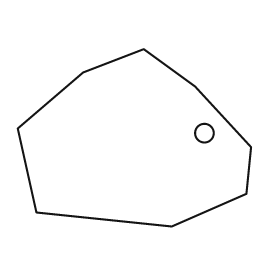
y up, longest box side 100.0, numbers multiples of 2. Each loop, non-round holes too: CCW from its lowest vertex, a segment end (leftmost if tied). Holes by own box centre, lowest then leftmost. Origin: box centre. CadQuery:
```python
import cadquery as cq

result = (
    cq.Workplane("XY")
    .moveTo(16.0, -38.0)
    .lineTo(48.0, -24.0)
    .lineTo(50.0, -4.0)
    .lineTo(26.0, 22.0)
    .lineTo(4.0, 38.0)
    .lineTo(-22.0, 28.0)
    .lineTo(-50.0, 4.0)
    .lineTo(-42.0, -32.0)
    .close()
    .moveTo(30.0, 2.0)
    .circle(4.0)
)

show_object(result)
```